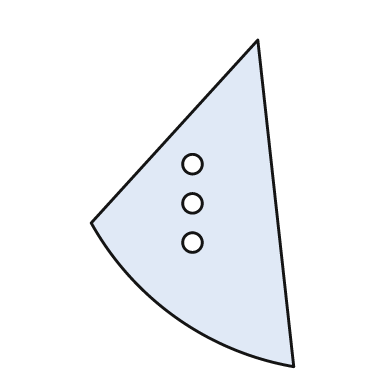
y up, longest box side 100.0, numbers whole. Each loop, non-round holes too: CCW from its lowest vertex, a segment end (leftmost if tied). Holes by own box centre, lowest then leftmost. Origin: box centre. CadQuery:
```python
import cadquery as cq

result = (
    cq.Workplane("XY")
    .moveTo(31.0, -50.0)
    .lineTo(20.0, 50.0)
    .lineTo(-31.0, -6.0)
    .threePointArc((-5.0, -35.0), (31.0, -50.0))
    .close()
    .moveTo(0.0, -12.0)
    .circle(3.0)
    .moveTo(0.0, 0.0)
    .circle(3.0)
    .moveTo(0.0, 12.0)
    .circle(3.0)
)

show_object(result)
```